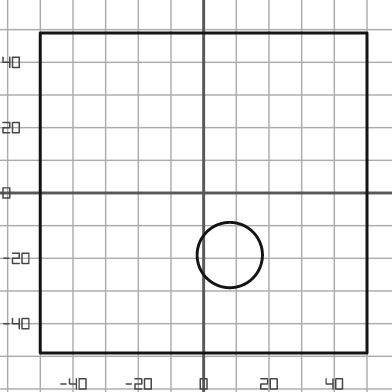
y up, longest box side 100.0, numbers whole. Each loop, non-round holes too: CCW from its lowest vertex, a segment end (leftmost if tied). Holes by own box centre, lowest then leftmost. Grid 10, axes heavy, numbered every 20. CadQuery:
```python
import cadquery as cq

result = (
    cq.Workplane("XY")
    .moveTo(-50.0, -49.0)
    .lineTo(50.0, -49.0)
    .lineTo(50.0, 49.0)
    .lineTo(-50.0, 49.0)
    .close()
    .moveTo(8.0, -19.0)
    .circle(10.0)
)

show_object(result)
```